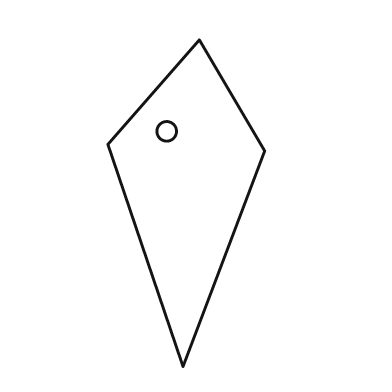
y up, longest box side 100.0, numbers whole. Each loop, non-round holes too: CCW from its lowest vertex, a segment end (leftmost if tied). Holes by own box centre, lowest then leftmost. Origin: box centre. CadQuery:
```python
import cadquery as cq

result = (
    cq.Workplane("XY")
    .moveTo(-1.0, -50.0)
    .lineTo(24.0, 16.0)
    .lineTo(4.0, 50.0)
    .lineTo(-24.0, 18.0)
    .close()
    .moveTo(-6.0, 22.0)
    .circle(3.0)
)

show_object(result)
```